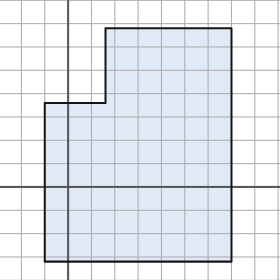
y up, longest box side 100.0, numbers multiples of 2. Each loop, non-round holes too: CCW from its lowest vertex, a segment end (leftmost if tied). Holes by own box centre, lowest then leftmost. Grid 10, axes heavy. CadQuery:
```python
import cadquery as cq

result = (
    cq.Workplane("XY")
    .moveTo(-10.0, -32.0)
    .lineTo(70.0, -32.0)
    .lineTo(70.0, 68.0)
    .lineTo(16.0, 68.0)
    .lineTo(16.0, 36.0)
    .lineTo(-10.0, 36.0)
    .close()
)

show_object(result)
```